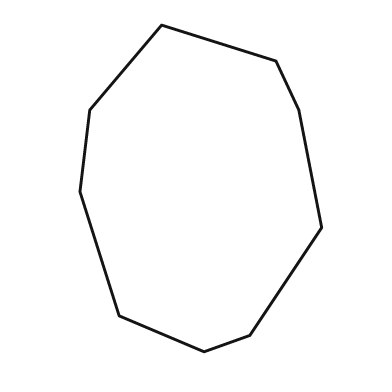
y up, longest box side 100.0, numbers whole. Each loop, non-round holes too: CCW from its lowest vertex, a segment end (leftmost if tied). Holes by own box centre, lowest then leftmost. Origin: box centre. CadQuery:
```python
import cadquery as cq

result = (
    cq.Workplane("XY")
    .moveTo(1.0, -50.0)
    .lineTo(15.0, -45.0)
    .lineTo(37.0, -12.0)
    .lineTo(30.0, 24.0)
    .lineTo(23.0, 39.0)
    .lineTo(-12.0, 50.0)
    .lineTo(-34.0, 24.0)
    .lineTo(-37.0, -1.0)
    .lineTo(-25.0, -39.0)
    .close()
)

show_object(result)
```